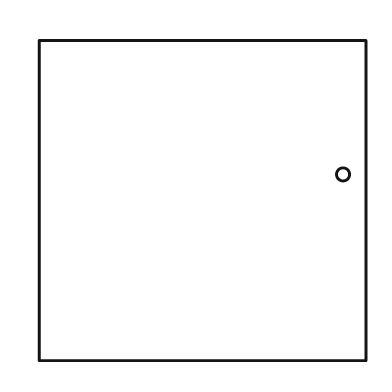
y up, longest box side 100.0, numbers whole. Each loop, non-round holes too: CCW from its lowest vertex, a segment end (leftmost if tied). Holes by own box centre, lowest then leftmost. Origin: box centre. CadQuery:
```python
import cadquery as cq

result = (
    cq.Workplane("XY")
    .moveTo(-50.0, -49.0)
    .lineTo(50.0, -49.0)
    .lineTo(50.0, 49.0)
    .lineTo(-50.0, 49.0)
    .close()
    .moveTo(43.0, 8.0)
    .circle(2.0)
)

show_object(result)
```